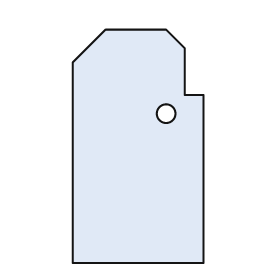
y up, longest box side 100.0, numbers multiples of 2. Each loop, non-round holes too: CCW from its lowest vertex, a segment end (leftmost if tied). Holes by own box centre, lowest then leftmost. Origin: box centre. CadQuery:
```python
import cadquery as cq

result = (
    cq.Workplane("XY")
    .moveTo(-28.0, -50.0)
    .lineTo(28.0, -50.0)
    .lineTo(28.0, 22.0)
    .lineTo(20.0, 22.0)
    .lineTo(20.0, 42.0)
    .lineTo(12.0, 50.0)
    .lineTo(-14.0, 50.0)
    .lineTo(-28.0, 36.0)
    .close()
    .moveTo(12.0, 14.0)
    .circle(4.0)
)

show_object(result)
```